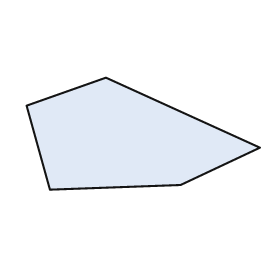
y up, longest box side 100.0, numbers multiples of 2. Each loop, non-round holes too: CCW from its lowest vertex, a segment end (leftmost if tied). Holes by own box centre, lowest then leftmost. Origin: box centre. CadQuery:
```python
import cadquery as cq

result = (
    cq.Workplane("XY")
    .moveTo(-40.0, -24.0)
    .lineTo(16.0, -22.0)
    .lineTo(50.0, -6.0)
    .lineTo(-16.0, 24.0)
    .lineTo(-50.0, 12.0)
    .close()
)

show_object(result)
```